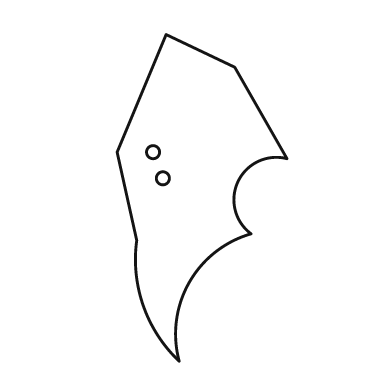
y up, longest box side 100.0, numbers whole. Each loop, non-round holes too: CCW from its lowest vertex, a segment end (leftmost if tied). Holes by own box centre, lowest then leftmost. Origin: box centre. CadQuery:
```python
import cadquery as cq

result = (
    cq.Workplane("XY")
    .moveTo(-7.0, -50.0)
    .threePointArc((-4.0, -26.0), (15.0, -11.0))
    .threePointArc((11.0, 5.0), (26.0, 12.0))
    .lineTo(10.0, 40.0)
    .lineTo(-11.0, 50.0)
    .lineTo(-26.0, 14.0)
    .lineTo(-20.0, -13.0)
    .threePointArc((-18.0, -33.0), (-7.0, -50.0))
    .close()
    .moveTo(-12.0, 6.0)
    .circle(2.0)
    .moveTo(-15.0, 14.0)
    .circle(2.0)
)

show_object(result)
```